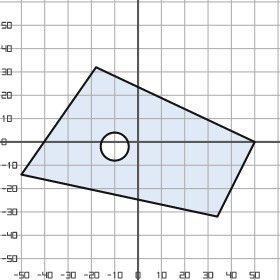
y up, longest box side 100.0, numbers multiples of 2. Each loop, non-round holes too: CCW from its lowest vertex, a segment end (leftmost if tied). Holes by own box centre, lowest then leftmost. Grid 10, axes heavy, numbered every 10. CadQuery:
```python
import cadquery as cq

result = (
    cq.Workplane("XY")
    .moveTo(34.0, -32.0)
    .lineTo(50.0, 0.0)
    .lineTo(-18.0, 32.0)
    .lineTo(-50.0, -14.0)
    .close()
    .moveTo(-10.0, -2.0)
    .circle(6.0)
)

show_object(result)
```